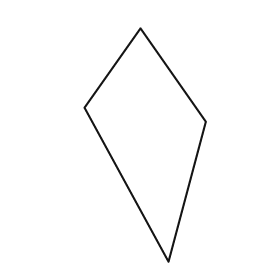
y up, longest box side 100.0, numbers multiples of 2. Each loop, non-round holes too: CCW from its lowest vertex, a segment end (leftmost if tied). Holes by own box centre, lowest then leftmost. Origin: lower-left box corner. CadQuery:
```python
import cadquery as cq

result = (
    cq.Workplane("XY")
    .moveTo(36.0, 0.0)
    .lineTo(52.0, 60.0)
    .lineTo(24.0, 100.0)
    .lineTo(0.0, 66.0)
    .close()
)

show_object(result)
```